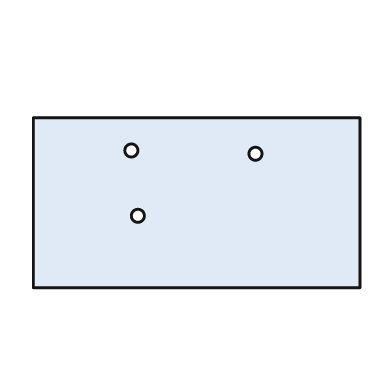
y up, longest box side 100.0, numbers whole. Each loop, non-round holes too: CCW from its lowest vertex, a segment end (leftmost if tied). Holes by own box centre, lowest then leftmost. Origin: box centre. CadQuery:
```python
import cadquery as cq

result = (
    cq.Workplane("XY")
    .moveTo(-50.0, -26.0)
    .lineTo(50.0, -26.0)
    .lineTo(50.0, 26.0)
    .lineTo(-50.0, 26.0)
    .close()
    .moveTo(-18.0, -4.0)
    .circle(2.0)
    .moveTo(18.0, 15.0)
    .circle(2.0)
    .moveTo(-20.0, 16.0)
    .circle(2.0)
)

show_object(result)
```